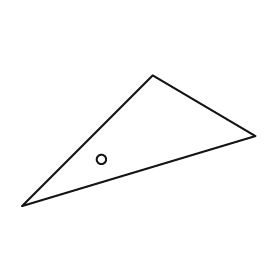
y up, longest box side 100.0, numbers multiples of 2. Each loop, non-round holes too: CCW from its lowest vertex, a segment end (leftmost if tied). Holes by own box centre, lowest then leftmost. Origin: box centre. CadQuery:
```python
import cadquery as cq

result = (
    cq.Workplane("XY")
    .moveTo(-50.0, -28.0)
    .lineTo(50.0, 2.0)
    .lineTo(6.0, 28.0)
    .close()
    .moveTo(-16.0, -8.0)
    .circle(2.0)
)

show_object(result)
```